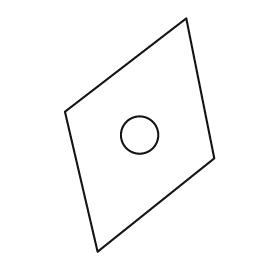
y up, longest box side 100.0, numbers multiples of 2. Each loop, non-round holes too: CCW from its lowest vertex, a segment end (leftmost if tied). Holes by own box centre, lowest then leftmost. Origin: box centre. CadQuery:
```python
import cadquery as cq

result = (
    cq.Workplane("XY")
    .moveTo(-18.0, -50.0)
    .lineTo(32.0, -10.0)
    .lineTo(20.0, 50.0)
    .lineTo(-32.0, 10.0)
    .close()
    .moveTo(0.0, 0.0)
    .circle(8.0)
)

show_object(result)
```